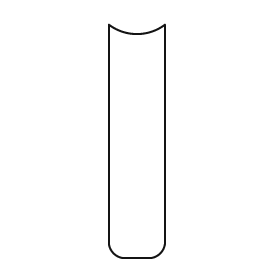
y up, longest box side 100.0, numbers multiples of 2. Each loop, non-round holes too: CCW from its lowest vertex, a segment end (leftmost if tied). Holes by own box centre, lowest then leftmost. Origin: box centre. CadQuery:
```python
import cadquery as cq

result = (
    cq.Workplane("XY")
    .moveTo(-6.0, -50.0)
    .lineTo(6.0, -50.0)
    .threePointArc((10.0, -48.0), (12.0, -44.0))
    .lineTo(12.0, 50.0)
    .threePointArc((0.0, 46.0), (-12.0, 50.0))
    .lineTo(-12.0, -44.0)
    .threePointArc((-10.0, -48.0), (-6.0, -50.0))
    .close()
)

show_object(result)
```